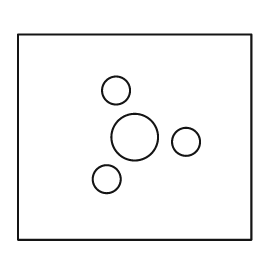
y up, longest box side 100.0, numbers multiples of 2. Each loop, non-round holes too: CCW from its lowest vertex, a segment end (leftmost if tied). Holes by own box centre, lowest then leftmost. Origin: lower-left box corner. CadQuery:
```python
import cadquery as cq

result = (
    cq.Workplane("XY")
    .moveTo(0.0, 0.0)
    .lineTo(100.0, 0.0)
    .lineTo(100.0, 88.0)
    .lineTo(0.0, 88.0)
    .close()
    .moveTo(38.0, 26.0)
    .circle(6.0)
    .moveTo(72.0, 42.0)
    .circle(6.0)
    .moveTo(50.0, 44.0)
    .circle(10.0)
    .moveTo(42.0, 64.0)
    .circle(6.0)
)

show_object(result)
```